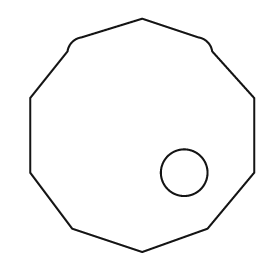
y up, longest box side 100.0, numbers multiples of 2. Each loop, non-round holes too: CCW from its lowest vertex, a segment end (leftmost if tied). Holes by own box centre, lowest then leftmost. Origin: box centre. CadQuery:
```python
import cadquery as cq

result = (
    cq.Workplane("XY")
    .moveTo(0.0, -50.0)
    .lineTo(28.0, -40.0)
    .lineTo(48.0, -16.0)
    .lineTo(48.0, 16.0)
    .lineTo(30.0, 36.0)
    .threePointArc((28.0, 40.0), (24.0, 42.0))
    .lineTo(0.0, 50.0)
    .lineTo(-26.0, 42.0)
    .threePointArc((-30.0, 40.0), (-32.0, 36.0))
    .lineTo(-48.0, 16.0)
    .lineTo(-48.0, -16.0)
    .lineTo(-30.0, -40.0)
    .close()
    .moveTo(18.0, -16.0)
    .circle(10.0)
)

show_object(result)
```